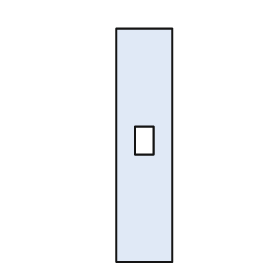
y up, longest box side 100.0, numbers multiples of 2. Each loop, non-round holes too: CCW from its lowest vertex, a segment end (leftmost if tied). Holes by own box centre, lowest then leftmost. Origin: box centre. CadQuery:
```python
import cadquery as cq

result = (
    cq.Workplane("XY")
    .moveTo(-12.0, -50.0)
    .lineTo(12.0, -50.0)
    .lineTo(12.0, 50.0)
    .lineTo(-12.0, 50.0)
    .close()
    .moveTo(-4.0, -4.0)
    .lineTo(4.0, -4.0)
    .lineTo(4.0, 8.0)
    .lineTo(-4.0, 8.0)
    .close()
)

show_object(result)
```